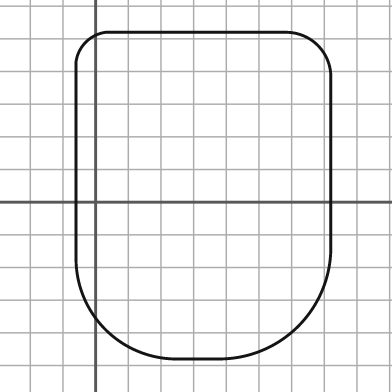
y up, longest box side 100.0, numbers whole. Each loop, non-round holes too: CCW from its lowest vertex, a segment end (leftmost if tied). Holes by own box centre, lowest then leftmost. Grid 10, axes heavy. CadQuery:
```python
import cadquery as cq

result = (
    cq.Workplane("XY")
    .moveTo(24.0, -48.0)
    .lineTo(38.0, -48.0)
    .threePointArc((62.0, -38.0), (72.0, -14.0))
    .lineTo(72.0, 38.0)
    .threePointArc((68.0, 48.0), (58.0, 52.0))
    .lineTo(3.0, 52.0)
    .threePointArc((-3.0, 49.0), (-6.0, 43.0))
    .lineTo(-6.0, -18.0)
    .threePointArc((3.0, -39.0), (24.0, -48.0))
    .close()
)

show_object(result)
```